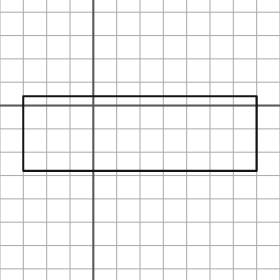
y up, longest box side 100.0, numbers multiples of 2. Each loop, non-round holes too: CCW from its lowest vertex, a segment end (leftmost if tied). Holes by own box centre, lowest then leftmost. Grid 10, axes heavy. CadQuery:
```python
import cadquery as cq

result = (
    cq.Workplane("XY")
    .moveTo(-30.0, -28.0)
    .lineTo(70.0, -28.0)
    .lineTo(70.0, 4.0)
    .lineTo(-30.0, 4.0)
    .close()
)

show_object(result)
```